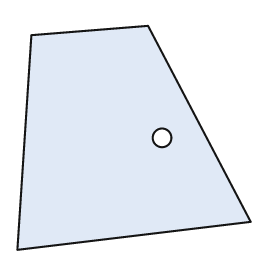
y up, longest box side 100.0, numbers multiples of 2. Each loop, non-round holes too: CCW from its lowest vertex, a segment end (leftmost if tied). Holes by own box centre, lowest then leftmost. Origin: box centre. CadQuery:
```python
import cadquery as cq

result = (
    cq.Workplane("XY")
    .moveTo(-50.0, -48.0)
    .lineTo(50.0, -36.0)
    .lineTo(6.0, 48.0)
    .lineTo(-44.0, 44.0)
    .close()
    .moveTo(12.0, 0.0)
    .circle(4.0)
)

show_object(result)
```